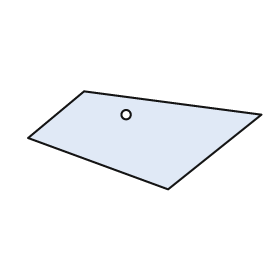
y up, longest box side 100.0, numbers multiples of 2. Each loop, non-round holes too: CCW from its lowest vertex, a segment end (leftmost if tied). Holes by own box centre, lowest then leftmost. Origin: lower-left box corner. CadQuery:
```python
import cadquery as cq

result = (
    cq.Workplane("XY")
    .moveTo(60.0, 0.0)
    .lineTo(100.0, 32.0)
    .lineTo(24.0, 42.0)
    .lineTo(0.0, 22.0)
    .close()
    .moveTo(42.0, 32.0)
    .circle(2.0)
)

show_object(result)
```